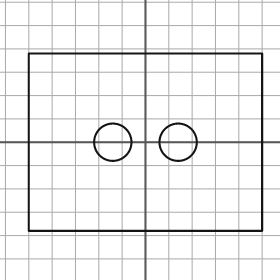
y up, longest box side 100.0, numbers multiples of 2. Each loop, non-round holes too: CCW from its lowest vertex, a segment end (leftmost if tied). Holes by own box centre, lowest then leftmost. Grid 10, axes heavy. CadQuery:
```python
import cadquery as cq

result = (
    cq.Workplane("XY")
    .moveTo(-50.0, -38.0)
    .lineTo(50.0, -38.0)
    .lineTo(50.0, 38.0)
    .lineTo(-50.0, 38.0)
    .close()
    .moveTo(-14.0, 0.0)
    .circle(8.0)
    .moveTo(14.0, 0.0)
    .circle(8.0)
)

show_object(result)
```